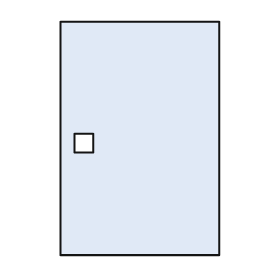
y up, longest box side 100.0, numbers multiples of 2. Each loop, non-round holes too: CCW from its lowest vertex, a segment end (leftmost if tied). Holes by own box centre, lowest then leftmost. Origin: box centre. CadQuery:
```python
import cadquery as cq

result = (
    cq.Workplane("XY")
    .moveTo(-34.0, -50.0)
    .lineTo(34.0, -50.0)
    .lineTo(34.0, 50.0)
    .lineTo(-34.0, 50.0)
    .close()
    .moveTo(-28.0, -6.0)
    .lineTo(-20.0, -6.0)
    .lineTo(-20.0, 2.0)
    .lineTo(-28.0, 2.0)
    .close()
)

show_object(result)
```